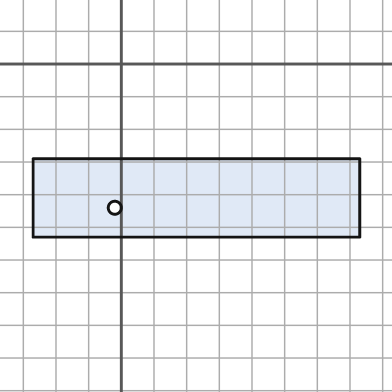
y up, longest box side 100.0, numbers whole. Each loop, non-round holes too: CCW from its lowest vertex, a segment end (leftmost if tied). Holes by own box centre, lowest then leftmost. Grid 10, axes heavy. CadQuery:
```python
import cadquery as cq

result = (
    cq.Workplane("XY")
    .moveTo(-27.0, -53.0)
    .lineTo(73.0, -53.0)
    .lineTo(73.0, -29.0)
    .lineTo(-27.0, -29.0)
    .close()
    .moveTo(-2.0, -44.0)
    .circle(2.0)
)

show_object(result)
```